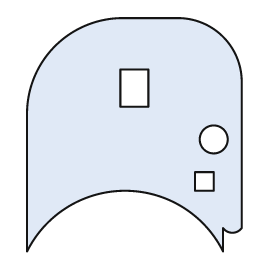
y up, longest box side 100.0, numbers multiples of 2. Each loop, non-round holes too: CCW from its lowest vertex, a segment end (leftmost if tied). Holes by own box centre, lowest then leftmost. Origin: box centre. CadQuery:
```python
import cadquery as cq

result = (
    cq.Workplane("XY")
    .moveTo(-46.0, -50.0)
    .threePointArc((-4.0, -24.0), (38.0, -50.0))
    .lineTo(38.0, -40.0)
    .threePointArc((42.0, -42.0), (46.0, -40.0))
    .lineTo(46.0, 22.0)
    .threePointArc((38.0, 42.0), (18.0, 50.0))
    .lineTo(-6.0, 50.0)
    .threePointArc((-34.0, 38.0), (-46.0, 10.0))
    .close()
    .moveTo(26.0, -24.0)
    .lineTo(34.0, -24.0)
    .lineTo(34.0, -16.0)
    .lineTo(26.0, -16.0)
    .close()
    .moveTo(34.0, -2.0)
    .circle(6.0)
    .moveTo(-6.0, 12.0)
    .lineTo(6.0, 12.0)
    .lineTo(6.0, 28.0)
    .lineTo(-6.0, 28.0)
    .close()
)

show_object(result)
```